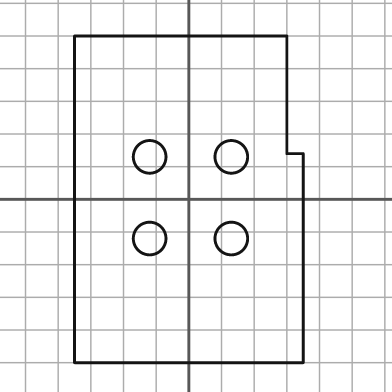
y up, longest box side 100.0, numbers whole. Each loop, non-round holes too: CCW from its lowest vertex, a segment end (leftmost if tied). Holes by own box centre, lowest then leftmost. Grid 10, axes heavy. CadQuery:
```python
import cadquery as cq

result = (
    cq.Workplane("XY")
    .moveTo(-35.0, -50.0)
    .lineTo(35.0, -50.0)
    .lineTo(35.0, 14.0)
    .lineTo(30.0, 14.0)
    .lineTo(30.0, 50.0)
    .lineTo(-35.0, 50.0)
    .close()
    .moveTo(-12.0, -12.0)
    .circle(5.0)
    .moveTo(13.0, -12.0)
    .circle(5.0)
    .moveTo(-12.0, 13.0)
    .circle(5.0)
    .moveTo(13.0, 13.0)
    .circle(5.0)
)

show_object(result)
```